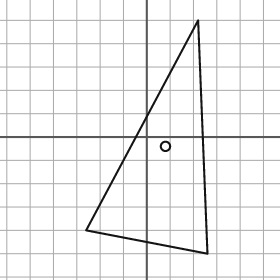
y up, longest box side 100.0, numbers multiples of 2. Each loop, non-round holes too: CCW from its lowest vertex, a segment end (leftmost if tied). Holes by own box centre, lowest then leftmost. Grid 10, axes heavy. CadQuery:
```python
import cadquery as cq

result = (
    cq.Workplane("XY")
    .moveTo(26.0, -50.0)
    .lineTo(22.0, 50.0)
    .lineTo(-26.0, -40.0)
    .close()
    .moveTo(8.0, -4.0)
    .circle(2.0)
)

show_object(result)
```